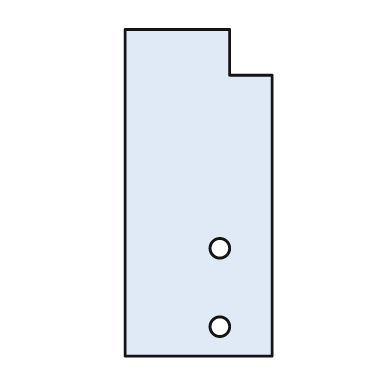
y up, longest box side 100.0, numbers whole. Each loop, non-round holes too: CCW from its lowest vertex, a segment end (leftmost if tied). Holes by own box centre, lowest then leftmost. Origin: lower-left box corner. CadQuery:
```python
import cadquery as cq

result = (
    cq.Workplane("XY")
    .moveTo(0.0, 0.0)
    .lineTo(45.0, 0.0)
    .lineTo(45.0, 86.0)
    .lineTo(32.0, 86.0)
    .lineTo(32.0, 100.0)
    .lineTo(0.0, 100.0)
    .close()
    .moveTo(29.0, 9.0)
    .circle(3.0)
    .moveTo(29.0, 33.0)
    .circle(3.0)
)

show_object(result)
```